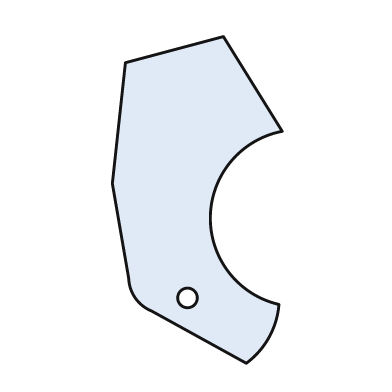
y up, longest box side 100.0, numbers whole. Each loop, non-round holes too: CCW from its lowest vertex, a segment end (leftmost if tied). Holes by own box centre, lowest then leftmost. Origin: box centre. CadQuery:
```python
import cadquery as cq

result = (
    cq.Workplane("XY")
    .moveTo(15.0, -50.0)
    .threePointArc((22.0, -42.0), (25.0, -32.0))
    .threePointArc((4.0, -5.0), (26.0, 21.0))
    .lineTo(8.0, 50.0)
    .lineTo(-22.0, 42.0)
    .lineTo(-26.0, 5.0)
    .lineTo(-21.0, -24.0)
    .threePointArc((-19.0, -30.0), (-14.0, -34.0))
    .close()
    .moveTo(-3.0, -30.0)
    .circle(3.0)
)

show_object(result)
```